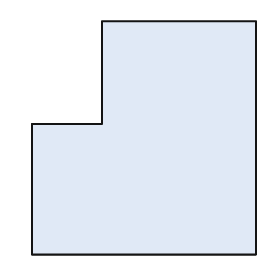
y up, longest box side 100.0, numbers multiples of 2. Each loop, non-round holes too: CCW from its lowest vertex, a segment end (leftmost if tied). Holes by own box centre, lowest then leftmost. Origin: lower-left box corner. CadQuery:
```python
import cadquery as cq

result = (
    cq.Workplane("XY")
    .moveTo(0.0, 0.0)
    .lineTo(96.0, 0.0)
    .lineTo(96.0, 100.0)
    .lineTo(30.0, 100.0)
    .lineTo(30.0, 56.0)
    .lineTo(0.0, 56.0)
    .close()
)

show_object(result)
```